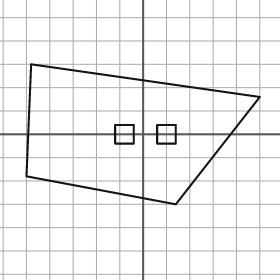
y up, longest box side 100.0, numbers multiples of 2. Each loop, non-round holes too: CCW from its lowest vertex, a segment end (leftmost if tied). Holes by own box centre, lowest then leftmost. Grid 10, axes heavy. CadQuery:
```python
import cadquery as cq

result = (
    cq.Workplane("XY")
    .moveTo(14.0, -30.0)
    .lineTo(50.0, 16.0)
    .lineTo(-48.0, 30.0)
    .lineTo(-50.0, -18.0)
    .close()
    .moveTo(-12.0, -4.0)
    .lineTo(-4.0, -4.0)
    .lineTo(-4.0, 4.0)
    .lineTo(-12.0, 4.0)
    .close()
    .moveTo(6.0, -4.0)
    .lineTo(14.0, -4.0)
    .lineTo(14.0, 4.0)
    .lineTo(6.0, 4.0)
    .close()
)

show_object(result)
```